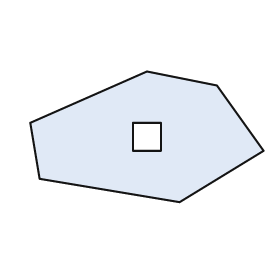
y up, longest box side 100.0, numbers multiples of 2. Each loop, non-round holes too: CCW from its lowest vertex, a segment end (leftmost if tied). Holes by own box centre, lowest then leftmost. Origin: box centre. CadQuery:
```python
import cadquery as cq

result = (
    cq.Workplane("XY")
    .moveTo(14.0, -28.0)
    .lineTo(50.0, -6.0)
    .lineTo(30.0, 22.0)
    .lineTo(0.0, 28.0)
    .lineTo(-50.0, 6.0)
    .lineTo(-46.0, -18.0)
    .close()
    .moveTo(-6.0, -6.0)
    .lineTo(6.0, -6.0)
    .lineTo(6.0, 6.0)
    .lineTo(-6.0, 6.0)
    .close()
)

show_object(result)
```